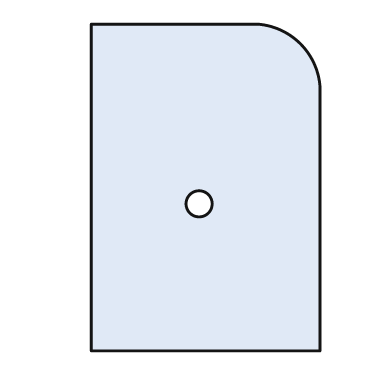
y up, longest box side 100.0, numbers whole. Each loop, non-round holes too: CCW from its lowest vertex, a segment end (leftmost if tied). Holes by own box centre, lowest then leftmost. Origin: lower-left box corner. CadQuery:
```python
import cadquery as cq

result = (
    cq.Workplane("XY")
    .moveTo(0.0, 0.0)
    .lineTo(70.0, 0.0)
    .lineTo(70.0, 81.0)
    .threePointArc((64.0, 94.0), (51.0, 100.0))
    .lineTo(0.0, 100.0)
    .close()
    .moveTo(33.0, 45.0)
    .circle(4.0)
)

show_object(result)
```